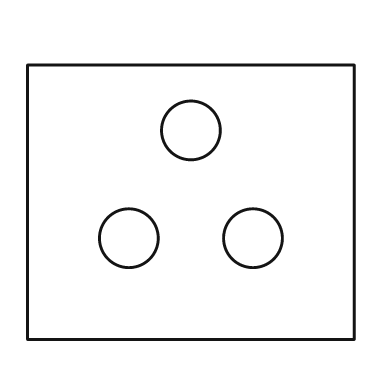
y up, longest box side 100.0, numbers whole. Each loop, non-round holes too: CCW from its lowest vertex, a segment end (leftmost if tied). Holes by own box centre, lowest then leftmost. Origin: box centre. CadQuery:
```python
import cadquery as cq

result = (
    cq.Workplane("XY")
    .moveTo(-50.0, -42.0)
    .lineTo(50.0, -42.0)
    .lineTo(50.0, 42.0)
    .lineTo(-50.0, 42.0)
    .close()
    .moveTo(-19.0, -11.0)
    .circle(9.0)
    .moveTo(19.0, -11.0)
    .circle(9.0)
    .moveTo(0.0, 22.0)
    .circle(9.0)
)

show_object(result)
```